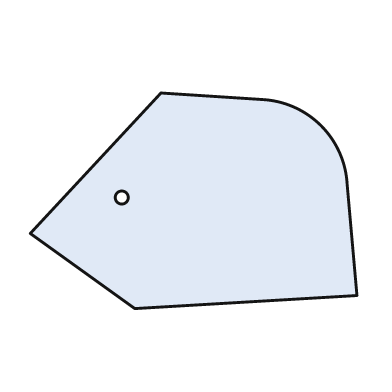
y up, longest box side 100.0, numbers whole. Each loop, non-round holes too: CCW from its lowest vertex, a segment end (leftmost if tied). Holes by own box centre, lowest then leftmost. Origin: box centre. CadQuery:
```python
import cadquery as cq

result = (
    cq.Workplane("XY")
    .moveTo(-18.0, -33.0)
    .lineTo(50.0, -29.0)
    .lineTo(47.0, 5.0)
    .threePointArc((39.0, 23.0), (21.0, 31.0))
    .lineTo(-10.0, 33.0)
    .lineTo(-50.0, -10.0)
    .close()
    .moveTo(-22.0, 1.0)
    .circle(2.0)
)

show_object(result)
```